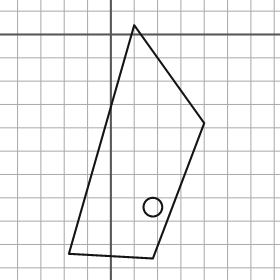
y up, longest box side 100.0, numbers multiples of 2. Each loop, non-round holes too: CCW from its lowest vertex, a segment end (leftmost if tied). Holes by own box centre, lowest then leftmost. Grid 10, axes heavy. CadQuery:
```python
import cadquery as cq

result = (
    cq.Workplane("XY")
    .moveTo(18.0, -96.0)
    .lineTo(40.0, -38.0)
    .lineTo(10.0, 4.0)
    .lineTo(-18.0, -94.0)
    .close()
    .moveTo(18.0, -74.0)
    .circle(4.0)
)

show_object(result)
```